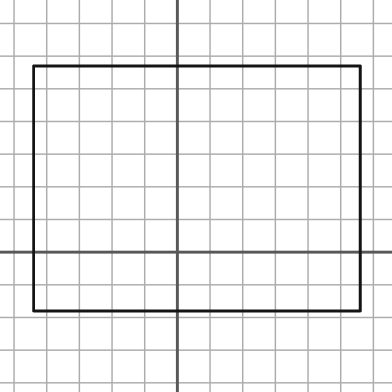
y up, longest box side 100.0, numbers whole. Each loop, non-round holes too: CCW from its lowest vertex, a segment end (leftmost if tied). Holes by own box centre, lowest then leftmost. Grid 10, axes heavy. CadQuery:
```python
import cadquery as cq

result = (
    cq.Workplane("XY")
    .moveTo(-44.0, -18.0)
    .lineTo(56.0, -18.0)
    .lineTo(56.0, 57.0)
    .lineTo(-44.0, 57.0)
    .close()
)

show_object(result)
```